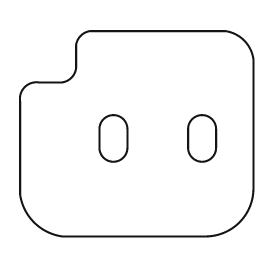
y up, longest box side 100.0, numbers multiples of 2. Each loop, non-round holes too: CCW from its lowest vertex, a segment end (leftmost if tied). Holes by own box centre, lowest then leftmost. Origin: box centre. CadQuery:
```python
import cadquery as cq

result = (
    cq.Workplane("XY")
    .moveTo(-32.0, -44.0)
    .lineTo(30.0, -44.0)
    .threePointArc((44.0, -38.0), (50.0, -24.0))
    .lineTo(50.0, 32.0)
    .threePointArc((46.0, 40.0), (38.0, 44.0))
    .lineTo(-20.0, 44.0)
    .threePointArc((-24.0, 42.0), (-26.0, 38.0))
    .lineTo(-26.0, 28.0)
    .threePointArc((-28.0, 24.0), (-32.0, 22.0))
    .lineTo(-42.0, 22.0)
    .threePointArc((-48.0, 20.0), (-50.0, 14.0))
    .lineTo(-50.0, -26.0)
    .threePointArc((-44.0, -38.0), (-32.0, -44.0))
    .close()
    .moveTo(-16.0, -6.0)
    .threePointArc((-10.0, -12.0), (-4.0, -6.0))
    .lineTo(-4.0, 2.0)
    .threePointArc((-10.0, 8.0), (-16.0, 2.0))
    .close()
    .moveTo(22.0, -6.0)
    .threePointArc((28.0, -12.0), (34.0, -6.0))
    .lineTo(34.0, 2.0)
    .threePointArc((28.0, 8.0), (22.0, 2.0))
    .close()
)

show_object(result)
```